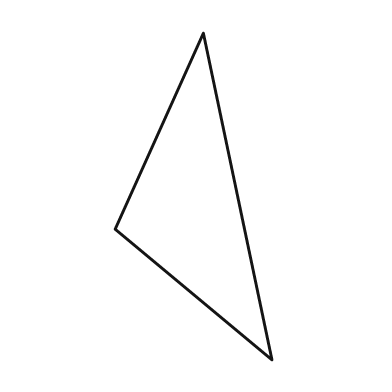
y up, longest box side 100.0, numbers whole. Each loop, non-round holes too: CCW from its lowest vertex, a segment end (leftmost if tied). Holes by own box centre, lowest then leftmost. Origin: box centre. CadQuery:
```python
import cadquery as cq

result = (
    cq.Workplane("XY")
    .moveTo(24.0, -50.0)
    .lineTo(3.0, 50.0)
    .lineTo(-24.0, -10.0)
    .close()
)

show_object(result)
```